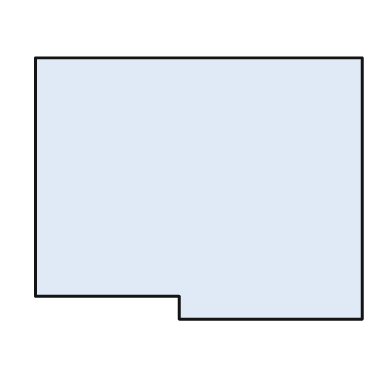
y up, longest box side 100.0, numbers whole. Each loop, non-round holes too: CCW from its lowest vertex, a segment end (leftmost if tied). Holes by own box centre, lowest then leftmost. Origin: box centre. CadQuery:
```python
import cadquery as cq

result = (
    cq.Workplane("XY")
    .moveTo(-6.0, -40.0)
    .lineTo(50.0, -40.0)
    .lineTo(50.0, 40.0)
    .lineTo(-50.0, 40.0)
    .lineTo(-50.0, -33.0)
    .lineTo(-6.0, -33.0)
    .close()
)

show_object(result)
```